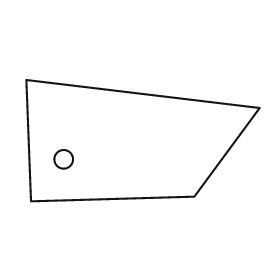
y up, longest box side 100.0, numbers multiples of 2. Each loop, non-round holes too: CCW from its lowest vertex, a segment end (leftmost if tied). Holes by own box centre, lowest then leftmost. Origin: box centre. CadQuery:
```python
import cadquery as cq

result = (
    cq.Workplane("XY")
    .moveTo(-48.0, -26.0)
    .lineTo(22.0, -24.0)
    .lineTo(50.0, 14.0)
    .lineTo(-50.0, 26.0)
    .close()
    .moveTo(-34.0, -8.0)
    .circle(4.0)
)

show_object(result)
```